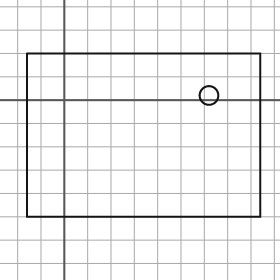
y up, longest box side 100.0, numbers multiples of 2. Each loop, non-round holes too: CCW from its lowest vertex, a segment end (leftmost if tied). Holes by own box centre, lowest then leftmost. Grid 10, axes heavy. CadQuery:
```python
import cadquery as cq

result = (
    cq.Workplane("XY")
    .moveTo(-16.0, -50.0)
    .lineTo(84.0, -50.0)
    .lineTo(84.0, 20.0)
    .lineTo(-16.0, 20.0)
    .close()
    .moveTo(62.0, 2.0)
    .circle(4.0)
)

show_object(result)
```